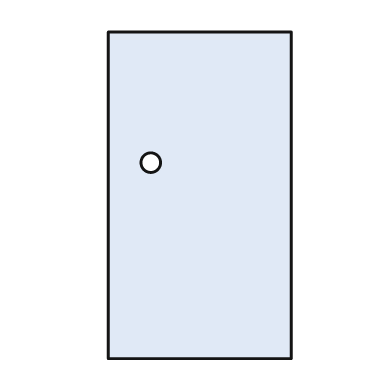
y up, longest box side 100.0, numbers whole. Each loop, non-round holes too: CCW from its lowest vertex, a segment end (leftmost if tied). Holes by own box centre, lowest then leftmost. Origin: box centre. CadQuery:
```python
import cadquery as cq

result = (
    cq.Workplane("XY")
    .moveTo(-28.0, -50.0)
    .lineTo(28.0, -50.0)
    .lineTo(28.0, 50.0)
    .lineTo(-28.0, 50.0)
    .close()
    .moveTo(-15.0, 10.0)
    .circle(3.0)
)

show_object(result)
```